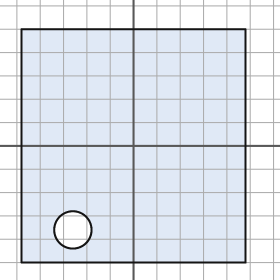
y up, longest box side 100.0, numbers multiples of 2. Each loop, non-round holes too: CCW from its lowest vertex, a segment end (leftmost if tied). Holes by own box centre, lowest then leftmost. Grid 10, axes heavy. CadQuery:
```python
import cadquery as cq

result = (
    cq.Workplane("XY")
    .moveTo(-48.0, -50.0)
    .lineTo(48.0, -50.0)
    .lineTo(48.0, 50.0)
    .lineTo(-48.0, 50.0)
    .close()
    .moveTo(-26.0, -36.0)
    .circle(8.0)
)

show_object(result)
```